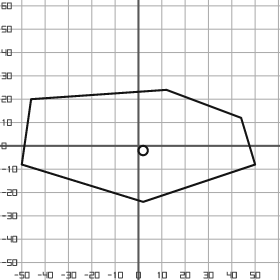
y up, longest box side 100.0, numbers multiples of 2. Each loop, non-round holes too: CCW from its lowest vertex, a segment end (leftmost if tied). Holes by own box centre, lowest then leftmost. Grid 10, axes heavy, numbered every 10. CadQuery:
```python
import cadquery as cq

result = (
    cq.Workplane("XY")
    .moveTo(2.0, -24.0)
    .lineTo(50.0, -8.0)
    .lineTo(44.0, 12.0)
    .lineTo(12.0, 24.0)
    .lineTo(-46.0, 20.0)
    .lineTo(-50.0, -8.0)
    .close()
    .moveTo(2.0, -2.0)
    .circle(2.0)
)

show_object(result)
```